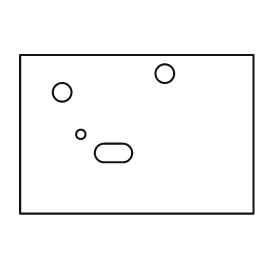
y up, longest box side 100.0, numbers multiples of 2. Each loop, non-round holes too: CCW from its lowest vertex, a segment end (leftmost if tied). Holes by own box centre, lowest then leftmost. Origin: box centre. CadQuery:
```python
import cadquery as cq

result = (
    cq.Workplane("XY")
    .moveTo(-50.0, -34.0)
    .lineTo(50.0, -34.0)
    .lineTo(50.0, 34.0)
    .lineTo(-50.0, 34.0)
    .close()
    .moveTo(-14.0, -12.0)
    .lineTo(-6.0, -12.0)
    .threePointArc((-2.0, -8.0), (-6.0, -4.0))
    .lineTo(-14.0, -4.0)
    .threePointArc((-18.0, -8.0), (-14.0, -12.0))
    .close()
    .moveTo(-24.0, 0.0)
    .circle(2.0)
    .moveTo(-32.0, 18.0)
    .circle(4.0)
    .moveTo(12.0, 26.0)
    .circle(4.0)
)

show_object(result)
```